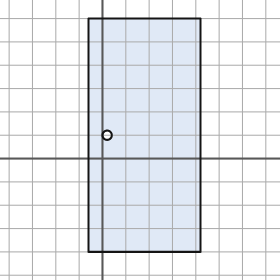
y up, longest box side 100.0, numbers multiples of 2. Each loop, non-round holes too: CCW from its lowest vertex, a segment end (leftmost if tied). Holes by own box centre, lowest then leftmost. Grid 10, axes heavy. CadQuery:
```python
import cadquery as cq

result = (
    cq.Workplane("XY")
    .moveTo(-6.0, -40.0)
    .lineTo(42.0, -40.0)
    .lineTo(42.0, 60.0)
    .lineTo(-6.0, 60.0)
    .close()
    .moveTo(2.0, 10.0)
    .circle(2.0)
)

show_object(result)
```